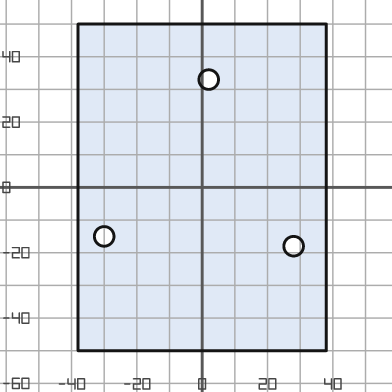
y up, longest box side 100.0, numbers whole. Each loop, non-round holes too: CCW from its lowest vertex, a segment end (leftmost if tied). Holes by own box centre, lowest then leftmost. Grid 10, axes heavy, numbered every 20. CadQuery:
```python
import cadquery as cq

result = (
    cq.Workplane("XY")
    .moveTo(-38.0, -50.0)
    .lineTo(38.0, -50.0)
    .lineTo(38.0, 50.0)
    .lineTo(-38.0, 50.0)
    .close()
    .moveTo(28.0, -18.0)
    .circle(3.0)
    .moveTo(-30.0, -15.0)
    .circle(3.0)
    .moveTo(2.0, 33.0)
    .circle(3.0)
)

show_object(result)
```